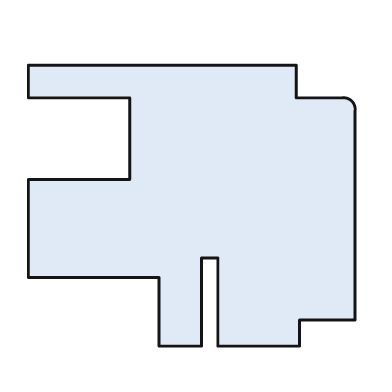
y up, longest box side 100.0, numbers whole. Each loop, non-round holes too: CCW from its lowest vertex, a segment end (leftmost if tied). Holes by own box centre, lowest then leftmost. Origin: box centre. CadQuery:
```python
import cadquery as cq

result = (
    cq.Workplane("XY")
    .moveTo(-10.0, -43.0)
    .lineTo(3.0, -43.0)
    .lineTo(3.0, -16.0)
    .lineTo(8.0, -16.0)
    .lineTo(8.0, -43.0)
    .lineTo(33.0, -43.0)
    .lineTo(33.0, -35.0)
    .lineTo(50.0, -35.0)
    .lineTo(50.0, 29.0)
    .threePointArc((49.0, 32.0), (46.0, 33.0))
    .lineTo(32.0, 33.0)
    .lineTo(32.0, 43.0)
    .lineTo(-50.0, 43.0)
    .lineTo(-50.0, 33.0)
    .lineTo(-19.0, 33.0)
    .lineTo(-19.0, 8.0)
    .lineTo(-50.0, 8.0)
    .lineTo(-50.0, -22.0)
    .lineTo(-10.0, -22.0)
    .close()
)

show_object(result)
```